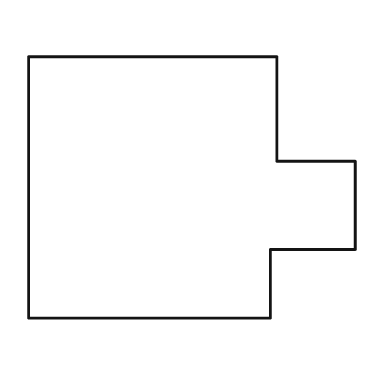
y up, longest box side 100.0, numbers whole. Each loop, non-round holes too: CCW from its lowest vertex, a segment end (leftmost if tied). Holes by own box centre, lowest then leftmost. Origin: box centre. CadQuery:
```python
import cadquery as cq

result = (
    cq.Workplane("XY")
    .moveTo(-50.0, -40.0)
    .lineTo(24.0, -40.0)
    .lineTo(24.0, -19.0)
    .lineTo(50.0, -19.0)
    .lineTo(50.0, 8.0)
    .lineTo(26.0, 8.0)
    .lineTo(26.0, 40.0)
    .lineTo(-50.0, 40.0)
    .close()
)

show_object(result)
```